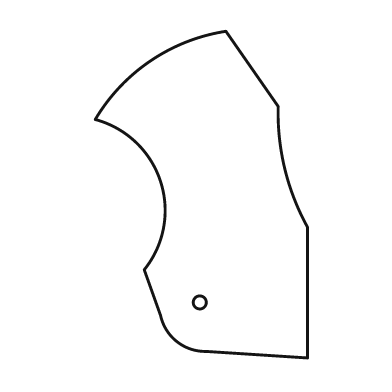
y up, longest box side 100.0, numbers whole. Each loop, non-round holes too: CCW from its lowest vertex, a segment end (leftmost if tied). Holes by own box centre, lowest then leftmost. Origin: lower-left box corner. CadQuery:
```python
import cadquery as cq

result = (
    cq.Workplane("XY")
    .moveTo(65.0, 0.0)
    .lineTo(65.0, 40.0)
    .threePointArc((58.0, 58.0), (56.0, 77.0))
    .lineTo(40.0, 100.0)
    .threePointArc((17.0, 91.0), (0.0, 73.0))
    .threePointArc((20.0, 54.0), (15.0, 27.0))
    .lineTo(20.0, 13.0)
    .threePointArc((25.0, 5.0), (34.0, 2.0))
    .close()
    .moveTo(32.0, 17.0)
    .circle(2.0)
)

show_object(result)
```